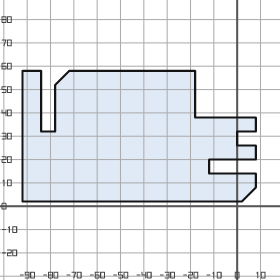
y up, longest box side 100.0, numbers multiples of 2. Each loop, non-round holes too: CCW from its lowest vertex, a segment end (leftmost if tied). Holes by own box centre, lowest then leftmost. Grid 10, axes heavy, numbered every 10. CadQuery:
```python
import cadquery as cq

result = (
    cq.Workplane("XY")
    .moveTo(-92.0, 2.0)
    .lineTo(2.0, 2.0)
    .lineTo(8.0, 8.0)
    .lineTo(8.0, 14.0)
    .lineTo(-12.0, 14.0)
    .lineTo(-12.0, 20.0)
    .lineTo(8.0, 20.0)
    .lineTo(8.0, 26.0)
    .lineTo(0.0, 26.0)
    .lineTo(0.0, 32.0)
    .lineTo(8.0, 32.0)
    .lineTo(8.0, 38.0)
    .lineTo(-18.0, 38.0)
    .lineTo(-18.0, 58.0)
    .lineTo(-72.0, 58.0)
    .lineTo(-78.0, 52.0)
    .lineTo(-78.0, 32.0)
    .lineTo(-84.0, 32.0)
    .lineTo(-84.0, 58.0)
    .lineTo(-92.0, 58.0)
    .close()
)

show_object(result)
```